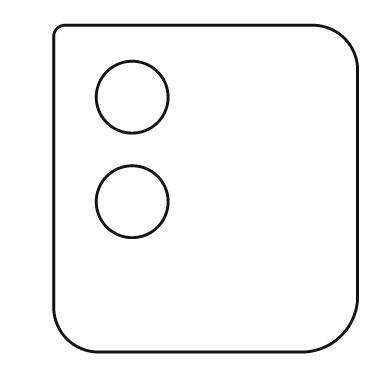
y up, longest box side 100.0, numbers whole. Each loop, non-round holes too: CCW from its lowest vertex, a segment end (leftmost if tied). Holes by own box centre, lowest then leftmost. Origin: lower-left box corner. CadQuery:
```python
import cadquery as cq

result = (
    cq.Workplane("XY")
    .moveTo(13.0, 0.0)
    .lineTo(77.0, 0.0)
    .threePointArc((88.0, 5.0), (93.0, 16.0))
    .lineTo(93.0, 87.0)
    .threePointArc((89.0, 96.0), (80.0, 100.0))
    .lineTo(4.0, 100.0)
    .threePointArc((1.0, 99.0), (0.0, 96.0))
    .lineTo(0.0, 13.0)
    .threePointArc((4.0, 4.0), (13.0, 0.0))
    .close()
    .moveTo(24.0, 46.0)
    .circle(11.0)
    .moveTo(24.0, 78.0)
    .circle(11.0)
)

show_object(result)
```